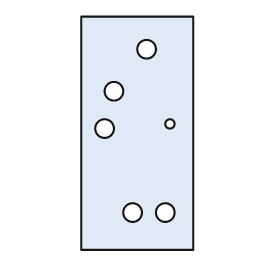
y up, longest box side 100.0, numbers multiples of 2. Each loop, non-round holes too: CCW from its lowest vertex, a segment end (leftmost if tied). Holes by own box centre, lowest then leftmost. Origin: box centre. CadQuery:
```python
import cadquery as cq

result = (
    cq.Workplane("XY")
    .moveTo(-24.0, -50.0)
    .lineTo(24.0, -50.0)
    .lineTo(24.0, 50.0)
    .lineTo(-24.0, 50.0)
    .close()
    .moveTo(-2.0, -34.0)
    .circle(4.0)
    .moveTo(12.0, -34.0)
    .circle(4.0)
    .moveTo(-14.0, 2.0)
    .circle(4.0)
    .moveTo(14.0, 4.0)
    .circle(2.0)
    .moveTo(-10.0, 18.0)
    .circle(4.0)
    .moveTo(4.0, 36.0)
    .circle(4.0)
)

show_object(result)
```